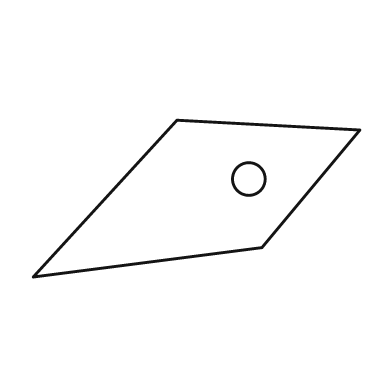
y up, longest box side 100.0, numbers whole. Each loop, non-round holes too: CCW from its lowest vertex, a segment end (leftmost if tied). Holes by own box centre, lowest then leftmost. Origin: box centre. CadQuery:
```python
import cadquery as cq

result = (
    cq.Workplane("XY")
    .moveTo(-50.0, -24.0)
    .lineTo(20.0, -15.0)
    .lineTo(50.0, 21.0)
    .lineTo(-6.0, 24.0)
    .close()
    .moveTo(16.0, 6.0)
    .circle(5.0)
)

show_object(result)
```